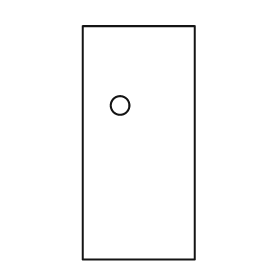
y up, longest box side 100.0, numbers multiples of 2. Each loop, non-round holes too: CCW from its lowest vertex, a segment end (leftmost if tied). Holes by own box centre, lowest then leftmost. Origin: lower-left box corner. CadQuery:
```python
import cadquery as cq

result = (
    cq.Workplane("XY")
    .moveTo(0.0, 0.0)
    .lineTo(48.0, 0.0)
    .lineTo(48.0, 100.0)
    .lineTo(0.0, 100.0)
    .close()
    .moveTo(16.0, 66.0)
    .circle(4.0)
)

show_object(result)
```